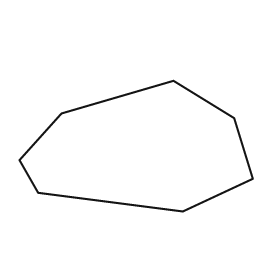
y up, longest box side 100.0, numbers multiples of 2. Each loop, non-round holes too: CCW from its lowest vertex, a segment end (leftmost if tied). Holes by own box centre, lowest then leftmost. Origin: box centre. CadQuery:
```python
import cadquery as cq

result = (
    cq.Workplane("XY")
    .moveTo(20.0, -28.0)
    .lineTo(50.0, -14.0)
    .lineTo(42.0, 12.0)
    .lineTo(16.0, 28.0)
    .lineTo(-32.0, 14.0)
    .lineTo(-50.0, -6.0)
    .lineTo(-42.0, -20.0)
    .close()
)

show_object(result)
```